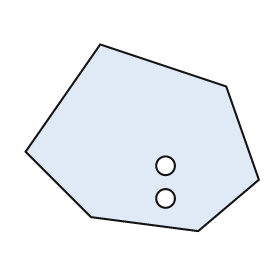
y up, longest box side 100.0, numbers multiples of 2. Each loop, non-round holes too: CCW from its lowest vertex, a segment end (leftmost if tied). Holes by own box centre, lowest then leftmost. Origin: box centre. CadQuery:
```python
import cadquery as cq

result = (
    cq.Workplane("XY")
    .moveTo(24.0, -40.0)
    .lineTo(50.0, -18.0)
    .lineTo(36.0, 22.0)
    .lineTo(-18.0, 40.0)
    .lineTo(-50.0, -6.0)
    .lineTo(-22.0, -34.0)
    .close()
    .moveTo(10.0, -26.0)
    .circle(4.0)
    .moveTo(10.0, -12.0)
    .circle(4.0)
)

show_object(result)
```